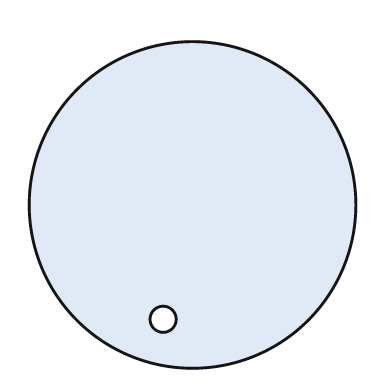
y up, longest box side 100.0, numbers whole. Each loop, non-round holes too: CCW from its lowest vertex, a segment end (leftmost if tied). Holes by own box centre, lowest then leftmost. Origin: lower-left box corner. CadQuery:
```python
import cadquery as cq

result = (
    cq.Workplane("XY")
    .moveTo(50.0, 50.0)
    .circle(50.0)
    .moveTo(41.0, 15.0)
    .circle(4.0)
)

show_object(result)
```